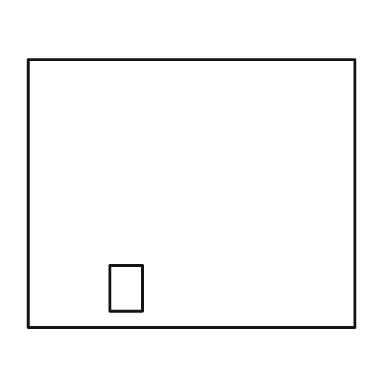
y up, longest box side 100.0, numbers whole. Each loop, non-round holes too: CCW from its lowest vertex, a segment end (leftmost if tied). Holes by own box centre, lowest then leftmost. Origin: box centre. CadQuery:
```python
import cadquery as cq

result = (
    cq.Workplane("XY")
    .moveTo(-50.0, -41.0)
    .lineTo(50.0, -41.0)
    .lineTo(50.0, 41.0)
    .lineTo(-50.0, 41.0)
    .close()
    .moveTo(-25.0, -36.0)
    .lineTo(-15.0, -36.0)
    .lineTo(-15.0, -22.0)
    .lineTo(-25.0, -22.0)
    .close()
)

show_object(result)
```